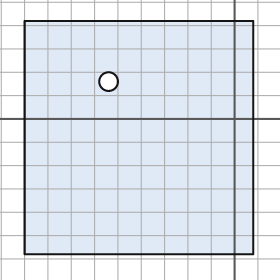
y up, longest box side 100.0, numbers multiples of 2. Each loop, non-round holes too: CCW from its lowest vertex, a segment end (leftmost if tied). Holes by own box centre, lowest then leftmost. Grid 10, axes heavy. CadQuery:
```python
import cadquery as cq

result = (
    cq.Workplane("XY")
    .moveTo(-90.0, -58.0)
    .lineTo(8.0, -58.0)
    .lineTo(8.0, 42.0)
    .lineTo(-90.0, 42.0)
    .close()
    .moveTo(-54.0, 16.0)
    .circle(4.0)
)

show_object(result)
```